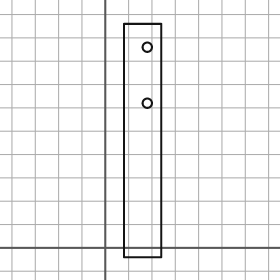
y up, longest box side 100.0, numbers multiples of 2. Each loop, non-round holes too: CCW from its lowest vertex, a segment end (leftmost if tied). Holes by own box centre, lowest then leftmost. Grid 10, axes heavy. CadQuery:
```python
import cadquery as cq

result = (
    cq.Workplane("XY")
    .moveTo(8.0, -4.0)
    .lineTo(24.0, -4.0)
    .lineTo(24.0, 96.0)
    .lineTo(8.0, 96.0)
    .close()
    .moveTo(18.0, 62.0)
    .circle(2.0)
    .moveTo(18.0, 86.0)
    .circle(2.0)
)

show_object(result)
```